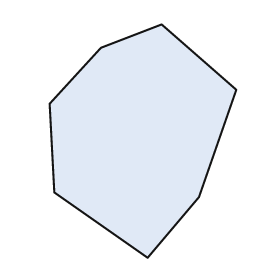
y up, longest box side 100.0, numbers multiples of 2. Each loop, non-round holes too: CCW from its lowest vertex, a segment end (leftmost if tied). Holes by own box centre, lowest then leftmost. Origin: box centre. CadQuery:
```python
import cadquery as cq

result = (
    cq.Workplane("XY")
    .moveTo(2.0, -50.0)
    .lineTo(24.0, -24.0)
    .lineTo(40.0, 22.0)
    .lineTo(8.0, 50.0)
    .lineTo(-18.0, 40.0)
    .lineTo(-40.0, 16.0)
    .lineTo(-38.0, -22.0)
    .close()
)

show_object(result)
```